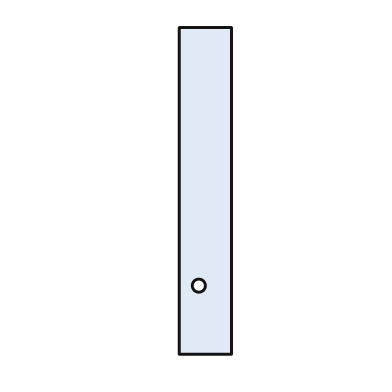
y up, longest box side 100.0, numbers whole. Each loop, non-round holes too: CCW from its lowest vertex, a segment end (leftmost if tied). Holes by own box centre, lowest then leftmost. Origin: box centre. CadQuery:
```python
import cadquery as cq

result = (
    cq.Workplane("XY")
    .moveTo(-8.0, -50.0)
    .lineTo(8.0, -50.0)
    .lineTo(8.0, 50.0)
    .lineTo(-8.0, 50.0)
    .close()
    .moveTo(-2.0, -29.0)
    .circle(2.0)
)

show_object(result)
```